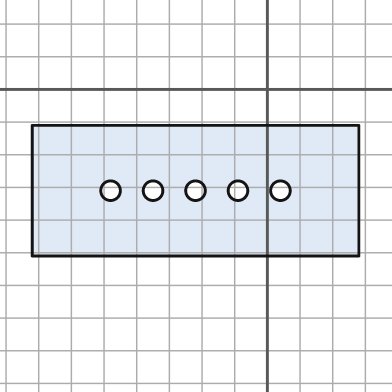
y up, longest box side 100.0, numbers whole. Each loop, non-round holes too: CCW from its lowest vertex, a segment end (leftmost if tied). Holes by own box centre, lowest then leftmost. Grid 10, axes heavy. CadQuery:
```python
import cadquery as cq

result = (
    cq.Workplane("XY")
    .moveTo(-72.0, -51.0)
    .lineTo(28.0, -51.0)
    .lineTo(28.0, -11.0)
    .lineTo(-72.0, -11.0)
    .close()
    .moveTo(-48.0, -31.0)
    .circle(3.0)
    .moveTo(-35.0, -31.0)
    .circle(3.0)
    .moveTo(-22.0, -31.0)
    .circle(3.0)
    .moveTo(-9.0, -31.0)
    .circle(3.0)
    .moveTo(4.0, -31.0)
    .circle(3.0)
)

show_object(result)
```